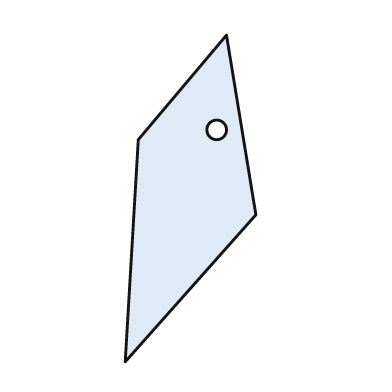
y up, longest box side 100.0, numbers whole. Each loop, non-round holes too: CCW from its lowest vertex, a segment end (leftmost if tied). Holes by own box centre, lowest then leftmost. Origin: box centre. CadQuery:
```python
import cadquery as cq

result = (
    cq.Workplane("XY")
    .moveTo(-20.0, -50.0)
    .lineTo(20.0, -5.0)
    .lineTo(11.0, 50.0)
    .lineTo(-16.0, 18.0)
    .close()
    .moveTo(8.0, 21.0)
    .circle(3.0)
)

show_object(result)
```